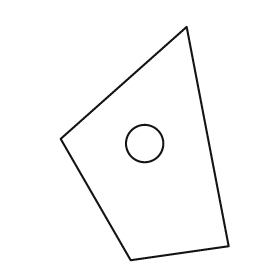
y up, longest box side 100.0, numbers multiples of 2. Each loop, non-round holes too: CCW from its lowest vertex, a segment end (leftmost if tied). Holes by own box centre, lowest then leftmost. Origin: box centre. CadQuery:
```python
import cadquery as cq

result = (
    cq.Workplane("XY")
    .moveTo(-6.0, -50.0)
    .lineTo(36.0, -44.0)
    .lineTo(18.0, 50.0)
    .lineTo(-36.0, 2.0)
    .close()
    .moveTo(0.0, 0.0)
    .circle(8.0)
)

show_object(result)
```